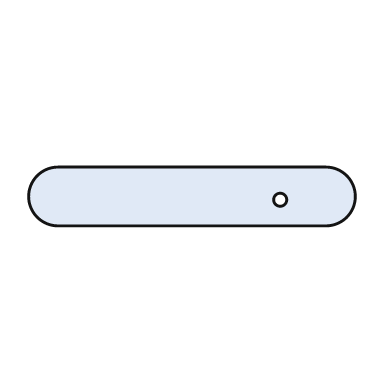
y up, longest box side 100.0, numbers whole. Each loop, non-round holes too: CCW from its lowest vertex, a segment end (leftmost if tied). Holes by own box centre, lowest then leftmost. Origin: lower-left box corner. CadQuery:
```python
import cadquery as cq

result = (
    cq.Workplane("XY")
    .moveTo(9.0, 0.0)
    .lineTo(91.0, 0.0)
    .threePointArc((100.0, 9.0), (91.0, 18.0))
    .lineTo(9.0, 18.0)
    .threePointArc((0.0, 9.0), (9.0, 0.0))
    .close()
    .moveTo(77.0, 8.0)
    .circle(2.0)
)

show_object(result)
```